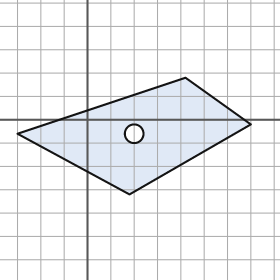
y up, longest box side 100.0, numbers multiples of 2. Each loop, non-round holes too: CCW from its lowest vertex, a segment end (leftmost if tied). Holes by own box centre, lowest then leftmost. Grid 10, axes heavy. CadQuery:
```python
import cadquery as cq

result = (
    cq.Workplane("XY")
    .moveTo(18.0, -32.0)
    .lineTo(70.0, -2.0)
    .lineTo(42.0, 18.0)
    .lineTo(-30.0, -6.0)
    .close()
    .moveTo(20.0, -6.0)
    .circle(4.0)
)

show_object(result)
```